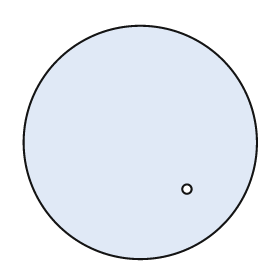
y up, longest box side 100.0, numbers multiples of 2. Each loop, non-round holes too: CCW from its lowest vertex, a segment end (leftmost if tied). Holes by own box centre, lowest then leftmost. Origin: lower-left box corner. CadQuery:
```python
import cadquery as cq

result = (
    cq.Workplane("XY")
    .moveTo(50.0, 50.0)
    .circle(50.0)
    .moveTo(70.0, 30.0)
    .circle(2.0)
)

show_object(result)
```